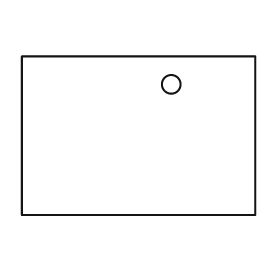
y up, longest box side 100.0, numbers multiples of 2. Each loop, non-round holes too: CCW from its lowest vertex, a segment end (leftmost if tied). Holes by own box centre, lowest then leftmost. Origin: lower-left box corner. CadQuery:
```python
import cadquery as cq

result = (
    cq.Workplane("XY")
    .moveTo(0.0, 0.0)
    .lineTo(100.0, 0.0)
    .lineTo(100.0, 68.0)
    .lineTo(0.0, 68.0)
    .close()
    .moveTo(64.0, 56.0)
    .circle(4.0)
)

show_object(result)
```